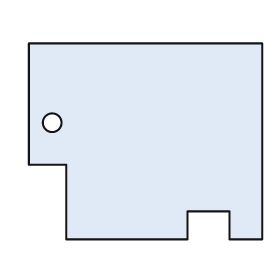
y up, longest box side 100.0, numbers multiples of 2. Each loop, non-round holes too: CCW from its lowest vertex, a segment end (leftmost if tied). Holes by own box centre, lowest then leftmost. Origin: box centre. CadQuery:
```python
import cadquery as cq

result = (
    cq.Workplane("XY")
    .moveTo(-34.0, -42.0)
    .lineTo(18.0, -42.0)
    .lineTo(18.0, -30.0)
    .lineTo(36.0, -30.0)
    .lineTo(36.0, -42.0)
    .lineTo(50.0, -42.0)
    .lineTo(50.0, 42.0)
    .lineTo(-50.0, 42.0)
    .lineTo(-50.0, -10.0)
    .lineTo(-34.0, -10.0)
    .close()
    .moveTo(-40.0, 8.0)
    .circle(4.0)
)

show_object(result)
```